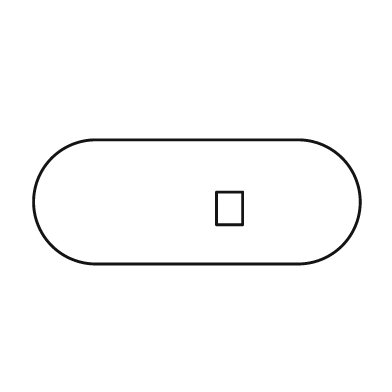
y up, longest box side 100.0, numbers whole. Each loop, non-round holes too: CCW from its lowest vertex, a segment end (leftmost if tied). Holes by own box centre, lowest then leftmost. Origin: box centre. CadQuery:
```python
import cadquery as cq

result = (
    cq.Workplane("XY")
    .moveTo(-31.0, -19.0)
    .lineTo(31.0, -19.0)
    .threePointArc((50.0, 0.0), (31.0, 19.0))
    .lineTo(-31.0, 19.0)
    .threePointArc((-50.0, 0.0), (-31.0, -19.0))
    .close()
    .moveTo(6.0, -7.0)
    .lineTo(14.0, -7.0)
    .lineTo(14.0, 3.0)
    .lineTo(6.0, 3.0)
    .close()
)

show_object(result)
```